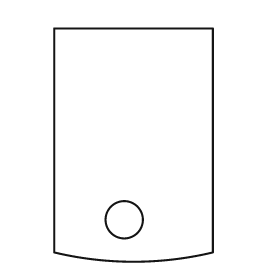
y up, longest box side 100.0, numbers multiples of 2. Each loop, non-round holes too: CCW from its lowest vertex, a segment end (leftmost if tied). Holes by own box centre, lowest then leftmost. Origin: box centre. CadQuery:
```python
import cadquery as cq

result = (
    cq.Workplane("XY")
    .moveTo(-34.0, -46.0)
    .threePointArc((0.0, -50.0), (34.0, -46.0))
    .lineTo(34.0, 50.0)
    .lineTo(-34.0, 50.0)
    .close()
    .moveTo(-4.0, -32.0)
    .circle(8.0)
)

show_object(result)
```